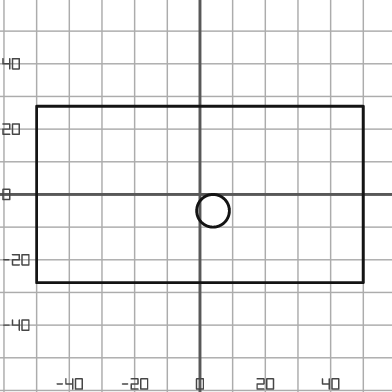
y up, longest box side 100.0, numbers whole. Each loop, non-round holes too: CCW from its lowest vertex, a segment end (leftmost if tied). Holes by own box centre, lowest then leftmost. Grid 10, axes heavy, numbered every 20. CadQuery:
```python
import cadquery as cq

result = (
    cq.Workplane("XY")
    .moveTo(-50.0, -27.0)
    .lineTo(50.0, -27.0)
    .lineTo(50.0, 27.0)
    .lineTo(-50.0, 27.0)
    .close()
    .moveTo(4.0, -5.0)
    .circle(5.0)
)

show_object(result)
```